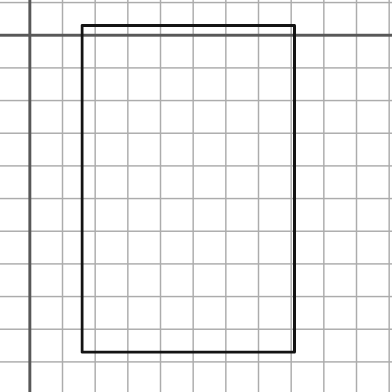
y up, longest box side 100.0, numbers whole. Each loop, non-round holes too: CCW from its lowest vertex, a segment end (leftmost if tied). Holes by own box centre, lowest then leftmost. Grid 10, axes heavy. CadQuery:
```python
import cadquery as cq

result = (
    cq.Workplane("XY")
    .moveTo(16.0, -97.0)
    .lineTo(81.0, -97.0)
    .lineTo(81.0, 3.0)
    .lineTo(16.0, 3.0)
    .close()
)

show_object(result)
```